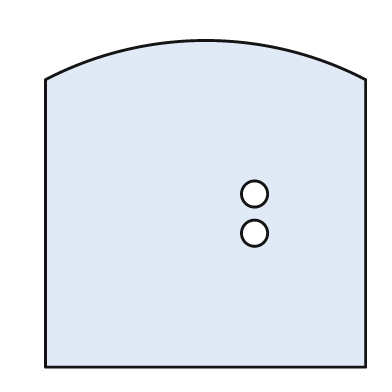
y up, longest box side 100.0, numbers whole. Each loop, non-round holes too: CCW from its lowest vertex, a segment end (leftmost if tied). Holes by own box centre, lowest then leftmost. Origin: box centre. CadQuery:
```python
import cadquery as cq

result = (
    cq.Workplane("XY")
    .moveTo(-49.0, -50.0)
    .lineTo(49.0, -50.0)
    .lineTo(49.0, 38.0)
    .threePointArc((0.0, 50.0), (-49.0, 38.0))
    .close()
    .moveTo(15.0, -9.0)
    .circle(4.0)
    .moveTo(15.0, 3.0)
    .circle(4.0)
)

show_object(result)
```